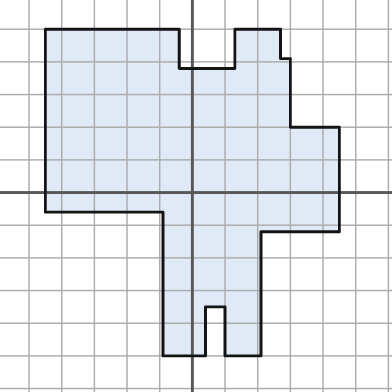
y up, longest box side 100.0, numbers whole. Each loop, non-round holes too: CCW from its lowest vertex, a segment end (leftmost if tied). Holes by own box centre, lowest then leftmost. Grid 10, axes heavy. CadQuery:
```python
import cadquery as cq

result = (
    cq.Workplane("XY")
    .moveTo(-9.0, -50.0)
    .lineTo(4.0, -50.0)
    .lineTo(4.0, -35.0)
    .lineTo(10.0, -35.0)
    .lineTo(10.0, -50.0)
    .lineTo(21.0, -50.0)
    .lineTo(21.0, -12.0)
    .lineTo(45.0, -12.0)
    .lineTo(45.0, 20.0)
    .lineTo(30.0, 20.0)
    .lineTo(30.0, 41.0)
    .lineTo(27.0, 41.0)
    .lineTo(27.0, 50.0)
    .lineTo(13.0, 50.0)
    .lineTo(13.0, 38.0)
    .lineTo(-4.0, 38.0)
    .lineTo(-4.0, 50.0)
    .lineTo(-45.0, 50.0)
    .lineTo(-45.0, -6.0)
    .lineTo(-9.0, -6.0)
    .close()
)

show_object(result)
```